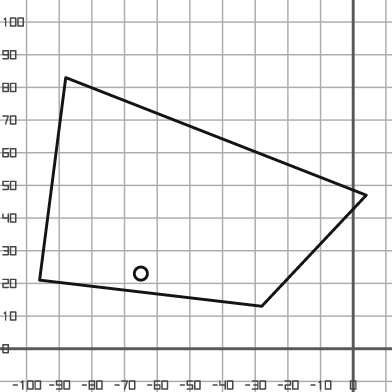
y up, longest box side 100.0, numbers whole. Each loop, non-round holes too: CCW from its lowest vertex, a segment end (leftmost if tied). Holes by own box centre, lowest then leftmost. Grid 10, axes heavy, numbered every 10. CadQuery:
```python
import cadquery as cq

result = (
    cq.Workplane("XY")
    .moveTo(-28.0, 13.0)
    .lineTo(4.0, 47.0)
    .lineTo(-88.0, 83.0)
    .lineTo(-96.0, 21.0)
    .close()
    .moveTo(-65.0, 23.0)
    .circle(2.0)
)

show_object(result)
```